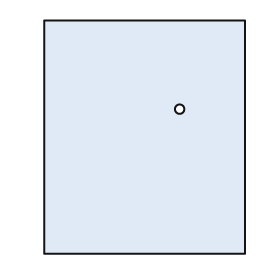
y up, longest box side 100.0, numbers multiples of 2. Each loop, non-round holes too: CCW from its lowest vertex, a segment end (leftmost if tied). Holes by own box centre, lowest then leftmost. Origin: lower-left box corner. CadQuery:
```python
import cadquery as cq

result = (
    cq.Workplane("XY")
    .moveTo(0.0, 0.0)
    .lineTo(86.0, 0.0)
    .lineTo(86.0, 100.0)
    .lineTo(0.0, 100.0)
    .close()
    .moveTo(58.0, 62.0)
    .circle(2.0)
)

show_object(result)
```